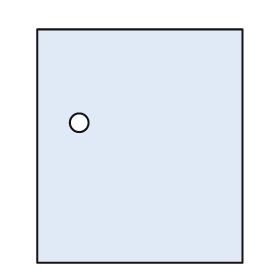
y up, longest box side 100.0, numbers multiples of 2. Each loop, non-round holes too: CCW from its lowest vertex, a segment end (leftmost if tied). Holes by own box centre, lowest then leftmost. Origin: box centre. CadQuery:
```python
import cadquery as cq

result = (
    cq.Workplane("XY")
    .moveTo(-44.0, -50.0)
    .lineTo(44.0, -50.0)
    .lineTo(44.0, 50.0)
    .lineTo(-44.0, 50.0)
    .close()
    .moveTo(-26.0, 10.0)
    .circle(4.0)
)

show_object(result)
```